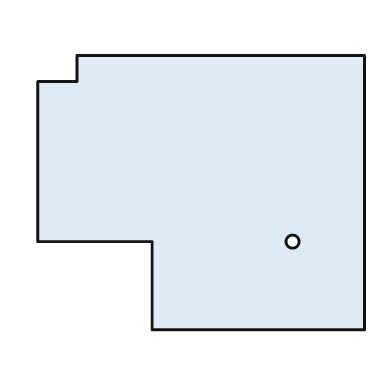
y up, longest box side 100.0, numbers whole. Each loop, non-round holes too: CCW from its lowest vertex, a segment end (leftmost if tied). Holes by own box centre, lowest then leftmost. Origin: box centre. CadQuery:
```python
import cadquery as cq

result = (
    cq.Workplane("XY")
    .moveTo(-15.0, -42.0)
    .lineTo(50.0, -42.0)
    .lineTo(50.0, 42.0)
    .lineTo(-38.0, 42.0)
    .lineTo(-38.0, 34.0)
    .lineTo(-50.0, 34.0)
    .lineTo(-50.0, -15.0)
    .lineTo(-15.0, -15.0)
    .close()
    .moveTo(28.0, -15.0)
    .circle(2.0)
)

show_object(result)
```